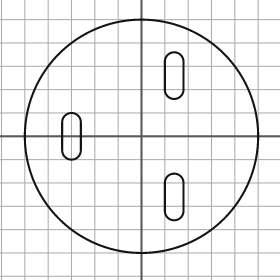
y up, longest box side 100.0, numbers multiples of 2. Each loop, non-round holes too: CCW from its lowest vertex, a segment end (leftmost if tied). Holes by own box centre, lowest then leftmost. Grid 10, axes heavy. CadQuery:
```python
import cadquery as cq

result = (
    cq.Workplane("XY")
    .moveTo(0.0, 0.0)
    .circle(50.0)
    .moveTo(10.0, -32.0)
    .threePointArc((14.0, -36.0), (18.0, -32.0))
    .lineTo(18.0, -20.0)
    .threePointArc((14.0, -16.0), (10.0, -20.0))
    .close()
    .moveTo(-34.0, -6.0)
    .threePointArc((-30.0, -10.0), (-26.0, -6.0))
    .lineTo(-26.0, 6.0)
    .threePointArc((-30.0, 10.0), (-34.0, 6.0))
    .close()
    .moveTo(10.0, 20.0)
    .threePointArc((14.0, 16.0), (18.0, 20.0))
    .lineTo(18.0, 32.0)
    .threePointArc((14.0, 36.0), (10.0, 32.0))
    .close()
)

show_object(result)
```